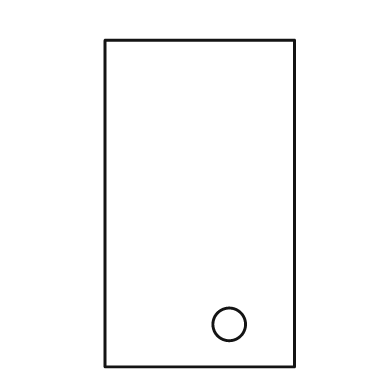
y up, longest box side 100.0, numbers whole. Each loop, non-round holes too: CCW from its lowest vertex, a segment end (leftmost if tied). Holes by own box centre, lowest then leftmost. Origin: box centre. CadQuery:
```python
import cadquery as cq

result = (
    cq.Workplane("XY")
    .moveTo(-29.0, -50.0)
    .lineTo(29.0, -50.0)
    .lineTo(29.0, 50.0)
    .lineTo(-29.0, 50.0)
    .close()
    .moveTo(9.0, -37.0)
    .circle(5.0)
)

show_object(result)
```